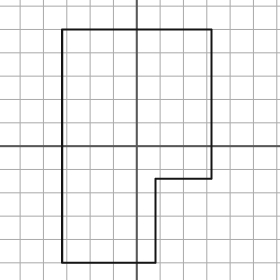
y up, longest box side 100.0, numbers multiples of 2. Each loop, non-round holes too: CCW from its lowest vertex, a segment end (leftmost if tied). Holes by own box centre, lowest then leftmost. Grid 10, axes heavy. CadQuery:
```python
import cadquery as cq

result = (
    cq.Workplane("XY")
    .moveTo(-32.0, -50.0)
    .lineTo(8.0, -50.0)
    .lineTo(8.0, -14.0)
    .lineTo(32.0, -14.0)
    .lineTo(32.0, 50.0)
    .lineTo(-32.0, 50.0)
    .close()
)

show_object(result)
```